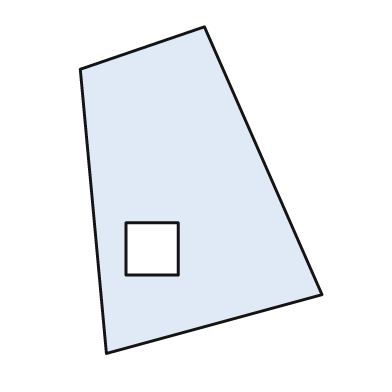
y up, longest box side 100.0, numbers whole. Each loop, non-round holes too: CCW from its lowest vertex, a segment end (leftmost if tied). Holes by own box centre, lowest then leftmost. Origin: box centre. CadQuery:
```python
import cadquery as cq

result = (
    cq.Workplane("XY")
    .moveTo(-29.0, -50.0)
    .lineTo(37.0, -32.0)
    .lineTo(1.0, 50.0)
    .lineTo(-37.0, 37.0)
    .close()
    .moveTo(-23.0, -26.0)
    .lineTo(-7.0, -26.0)
    .lineTo(-7.0, -10.0)
    .lineTo(-23.0, -10.0)
    .close()
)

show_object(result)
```